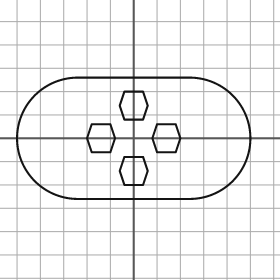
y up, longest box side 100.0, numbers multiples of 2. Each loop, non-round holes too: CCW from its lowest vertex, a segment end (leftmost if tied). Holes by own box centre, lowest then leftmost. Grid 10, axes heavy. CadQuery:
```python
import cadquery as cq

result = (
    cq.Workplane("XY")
    .moveTo(-24.0, -26.0)
    .lineTo(24.0, -26.0)
    .threePointArc((50.0, 0.0), (24.0, 26.0))
    .lineTo(-24.0, 26.0)
    .threePointArc((-50.0, 0.0), (-24.0, -26.0))
    .close()
    .moveTo(-4.0, -20.0)
    .lineTo(4.0, -20.0)
    .lineTo(6.0, -14.0)
    .lineTo(4.0, -8.0)
    .lineTo(-4.0, -8.0)
    .lineTo(-6.0, -14.0)
    .close()
    .moveTo(-18.0, -6.0)
    .lineTo(-10.0, -6.0)
    .lineTo(-8.0, 0.0)
    .lineTo(-10.0, 6.0)
    .lineTo(-18.0, 6.0)
    .lineTo(-20.0, 0.0)
    .close()
    .moveTo(10.0, -6.0)
    .lineTo(18.0, -6.0)
    .lineTo(20.0, 0.0)
    .lineTo(18.0, 6.0)
    .lineTo(10.0, 6.0)
    .lineTo(8.0, 0.0)
    .close()
    .moveTo(-4.0, 8.0)
    .lineTo(4.0, 8.0)
    .lineTo(6.0, 14.0)
    .lineTo(4.0, 20.0)
    .lineTo(-4.0, 20.0)
    .lineTo(-6.0, 14.0)
    .close()
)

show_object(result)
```